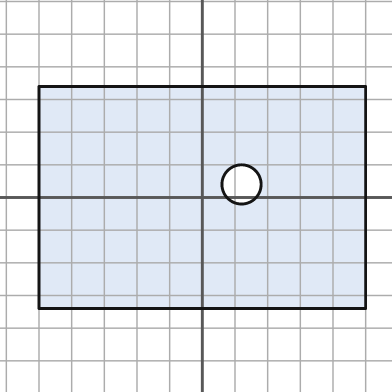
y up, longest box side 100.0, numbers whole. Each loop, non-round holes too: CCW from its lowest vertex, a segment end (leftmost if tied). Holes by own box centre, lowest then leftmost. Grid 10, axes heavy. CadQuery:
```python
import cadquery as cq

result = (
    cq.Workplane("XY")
    .moveTo(-50.0, -34.0)
    .lineTo(50.0, -34.0)
    .lineTo(50.0, 34.0)
    .lineTo(-50.0, 34.0)
    .close()
    .moveTo(12.0, 4.0)
    .circle(6.0)
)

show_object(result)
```